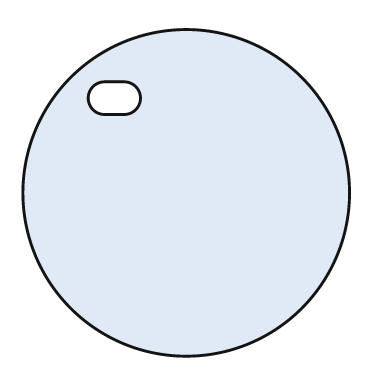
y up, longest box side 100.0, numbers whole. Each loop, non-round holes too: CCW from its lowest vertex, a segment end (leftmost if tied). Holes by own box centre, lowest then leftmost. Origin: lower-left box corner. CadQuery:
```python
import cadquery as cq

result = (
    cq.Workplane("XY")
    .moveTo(50.0, 50.0)
    .circle(50.0)
    .moveTo(25.0, 74.0)
    .lineTo(31.0, 74.0)
    .threePointArc((36.0, 79.0), (31.0, 84.0))
    .lineTo(25.0, 84.0)
    .threePointArc((20.0, 79.0), (25.0, 74.0))
    .close()
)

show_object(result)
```